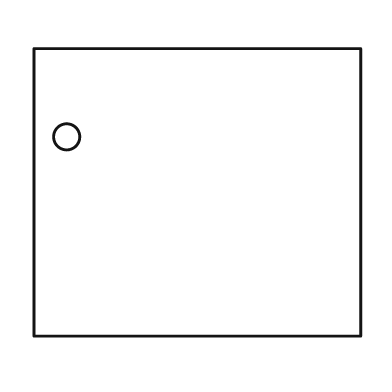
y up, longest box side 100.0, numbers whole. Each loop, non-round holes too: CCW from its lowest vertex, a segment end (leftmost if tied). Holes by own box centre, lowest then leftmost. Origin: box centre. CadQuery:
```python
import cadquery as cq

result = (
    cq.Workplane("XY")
    .moveTo(-50.0, -44.0)
    .lineTo(50.0, -44.0)
    .lineTo(50.0, 44.0)
    .lineTo(-50.0, 44.0)
    .close()
    .moveTo(-40.0, 17.0)
    .circle(4.0)
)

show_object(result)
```